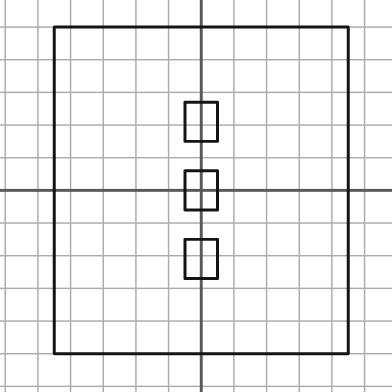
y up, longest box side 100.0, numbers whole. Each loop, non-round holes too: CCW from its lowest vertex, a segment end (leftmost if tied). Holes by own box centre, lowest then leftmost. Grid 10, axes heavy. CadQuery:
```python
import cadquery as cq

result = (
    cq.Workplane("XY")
    .moveTo(-45.0, -50.0)
    .lineTo(45.0, -50.0)
    .lineTo(45.0, 50.0)
    .lineTo(-45.0, 50.0)
    .close()
    .moveTo(-5.0, -27.0)
    .lineTo(5.0, -27.0)
    .lineTo(5.0, -15.0)
    .lineTo(-5.0, -15.0)
    .close()
    .moveTo(-5.0, -6.0)
    .lineTo(5.0, -6.0)
    .lineTo(5.0, 6.0)
    .lineTo(-5.0, 6.0)
    .close()
    .moveTo(-5.0, 15.0)
    .lineTo(5.0, 15.0)
    .lineTo(5.0, 27.0)
    .lineTo(-5.0, 27.0)
    .close()
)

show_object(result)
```